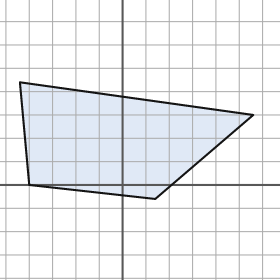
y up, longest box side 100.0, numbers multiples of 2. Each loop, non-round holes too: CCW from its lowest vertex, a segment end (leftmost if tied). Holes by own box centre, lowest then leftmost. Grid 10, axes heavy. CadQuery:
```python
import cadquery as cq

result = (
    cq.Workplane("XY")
    .moveTo(14.0, -6.0)
    .lineTo(56.0, 30.0)
    .lineTo(-44.0, 44.0)
    .lineTo(-40.0, 0.0)
    .close()
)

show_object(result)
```